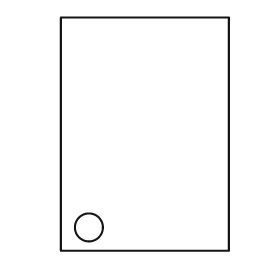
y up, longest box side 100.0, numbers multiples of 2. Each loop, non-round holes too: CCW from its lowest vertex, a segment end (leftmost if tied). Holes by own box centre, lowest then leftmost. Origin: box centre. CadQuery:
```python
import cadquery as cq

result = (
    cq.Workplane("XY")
    .moveTo(-36.0, -50.0)
    .lineTo(36.0, -50.0)
    .lineTo(36.0, 50.0)
    .lineTo(-36.0, 50.0)
    .close()
    .moveTo(-24.0, -40.0)
    .circle(6.0)
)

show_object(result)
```